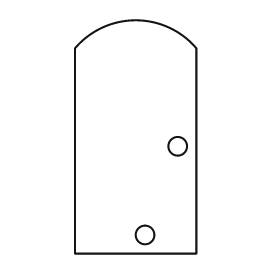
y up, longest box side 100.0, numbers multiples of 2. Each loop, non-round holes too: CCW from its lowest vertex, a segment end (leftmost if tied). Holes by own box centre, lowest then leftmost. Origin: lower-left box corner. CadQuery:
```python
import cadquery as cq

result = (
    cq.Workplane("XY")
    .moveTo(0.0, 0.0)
    .lineTo(52.0, 0.0)
    .lineTo(52.0, 88.0)
    .threePointArc((26.0, 100.0), (0.0, 88.0))
    .close()
    .moveTo(30.0, 8.0)
    .circle(4.0)
    .moveTo(44.0, 46.0)
    .circle(4.0)
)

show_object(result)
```